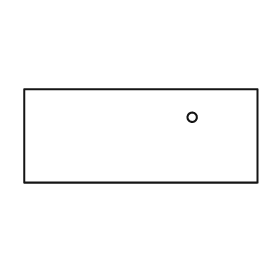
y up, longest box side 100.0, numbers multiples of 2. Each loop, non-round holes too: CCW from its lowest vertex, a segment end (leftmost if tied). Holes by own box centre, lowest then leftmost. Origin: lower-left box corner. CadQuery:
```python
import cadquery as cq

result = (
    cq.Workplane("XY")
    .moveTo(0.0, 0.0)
    .lineTo(100.0, 0.0)
    .lineTo(100.0, 40.0)
    .lineTo(0.0, 40.0)
    .close()
    .moveTo(72.0, 28.0)
    .circle(2.0)
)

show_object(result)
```